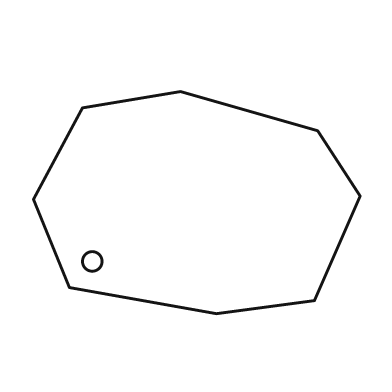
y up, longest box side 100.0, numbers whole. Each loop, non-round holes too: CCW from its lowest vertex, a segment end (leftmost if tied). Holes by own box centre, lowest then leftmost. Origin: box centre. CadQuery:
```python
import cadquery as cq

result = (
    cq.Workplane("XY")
    .moveTo(6.0, -34.0)
    .lineTo(36.0, -30.0)
    .lineTo(50.0, 2.0)
    .lineTo(37.0, 22.0)
    .lineTo(-5.0, 34.0)
    .lineTo(-35.0, 29.0)
    .lineTo(-50.0, 1.0)
    .lineTo(-39.0, -26.0)
    .close()
    .moveTo(-32.0, -18.0)
    .circle(3.0)
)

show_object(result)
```